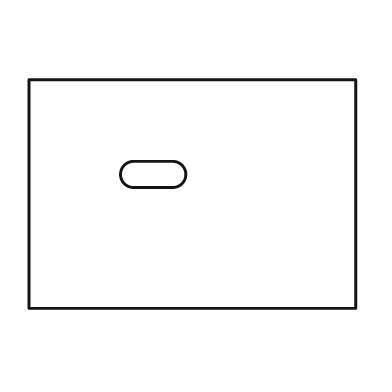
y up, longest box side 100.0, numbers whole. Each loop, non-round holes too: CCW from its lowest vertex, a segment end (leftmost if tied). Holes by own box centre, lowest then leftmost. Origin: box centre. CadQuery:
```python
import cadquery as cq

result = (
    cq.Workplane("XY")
    .moveTo(-50.0, -35.0)
    .lineTo(50.0, -35.0)
    .lineTo(50.0, 35.0)
    .lineTo(-50.0, 35.0)
    .close()
    .moveTo(-18.0, 2.0)
    .lineTo(-6.0, 2.0)
    .threePointArc((-2.0, 6.0), (-6.0, 10.0))
    .lineTo(-18.0, 10.0)
    .threePointArc((-22.0, 6.0), (-18.0, 2.0))
    .close()
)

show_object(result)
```